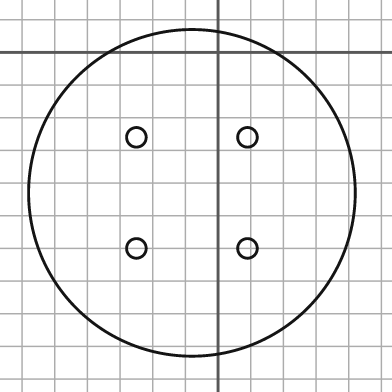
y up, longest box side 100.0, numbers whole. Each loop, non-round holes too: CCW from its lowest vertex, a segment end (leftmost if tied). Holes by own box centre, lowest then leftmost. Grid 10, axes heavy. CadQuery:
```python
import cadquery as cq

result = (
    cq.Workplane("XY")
    .moveTo(-8.0, -43.0)
    .circle(50.0)
    .moveTo(-25.0, -60.0)
    .circle(3.0)
    .moveTo(9.0, -60.0)
    .circle(3.0)
    .moveTo(-25.0, -26.0)
    .circle(3.0)
    .moveTo(9.0, -26.0)
    .circle(3.0)
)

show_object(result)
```